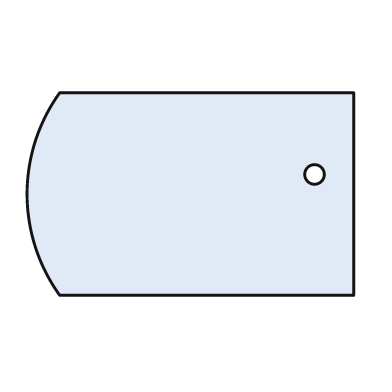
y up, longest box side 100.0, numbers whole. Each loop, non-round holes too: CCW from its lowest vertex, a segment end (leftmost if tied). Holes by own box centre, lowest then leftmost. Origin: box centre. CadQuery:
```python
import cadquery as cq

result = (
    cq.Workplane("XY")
    .moveTo(-40.0, -31.0)
    .lineTo(50.0, -31.0)
    .lineTo(50.0, 31.0)
    .lineTo(-40.0, 31.0)
    .threePointArc((-50.0, 0.0), (-40.0, -31.0))
    .close()
    .moveTo(38.0, 6.0)
    .circle(3.0)
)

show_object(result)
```